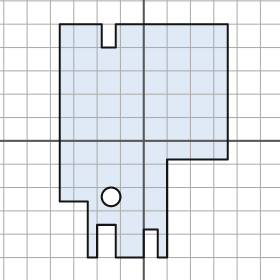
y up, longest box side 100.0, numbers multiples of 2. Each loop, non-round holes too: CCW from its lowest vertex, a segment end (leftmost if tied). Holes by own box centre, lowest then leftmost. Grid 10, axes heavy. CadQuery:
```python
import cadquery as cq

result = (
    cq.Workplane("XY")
    .moveTo(-24.0, -50.0)
    .lineTo(-20.0, -50.0)
    .lineTo(-20.0, -36.0)
    .lineTo(-12.0, -36.0)
    .lineTo(-12.0, -50.0)
    .lineTo(0.0, -50.0)
    .lineTo(0.0, -38.0)
    .lineTo(6.0, -38.0)
    .lineTo(6.0, -50.0)
    .lineTo(10.0, -50.0)
    .lineTo(10.0, -8.0)
    .lineTo(36.0, -8.0)
    .lineTo(36.0, 50.0)
    .lineTo(-12.0, 50.0)
    .lineTo(-12.0, 40.0)
    .lineTo(-18.0, 40.0)
    .lineTo(-18.0, 50.0)
    .lineTo(-36.0, 50.0)
    .lineTo(-36.0, -26.0)
    .lineTo(-24.0, -26.0)
    .close()
    .moveTo(-14.0, -24.0)
    .circle(4.0)
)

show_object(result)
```